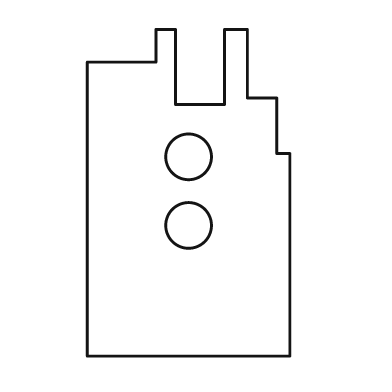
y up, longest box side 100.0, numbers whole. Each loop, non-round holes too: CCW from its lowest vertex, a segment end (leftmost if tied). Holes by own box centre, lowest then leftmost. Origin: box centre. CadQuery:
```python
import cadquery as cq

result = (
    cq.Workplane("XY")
    .moveTo(-31.0, -50.0)
    .lineTo(31.0, -50.0)
    .lineTo(31.0, 12.0)
    .lineTo(27.0, 12.0)
    .lineTo(27.0, 29.0)
    .lineTo(18.0, 29.0)
    .lineTo(18.0, 50.0)
    .lineTo(11.0, 50.0)
    .lineTo(11.0, 27.0)
    .lineTo(-4.0, 27.0)
    .lineTo(-4.0, 50.0)
    .lineTo(-10.0, 50.0)
    .lineTo(-10.0, 40.0)
    .lineTo(-31.0, 40.0)
    .close()
    .moveTo(0.0, -10.0)
    .circle(7.0)
    .moveTo(0.0, 11.0)
    .circle(7.0)
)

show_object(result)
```